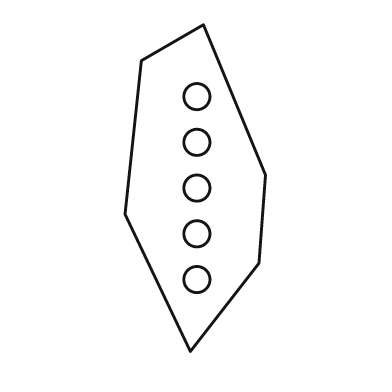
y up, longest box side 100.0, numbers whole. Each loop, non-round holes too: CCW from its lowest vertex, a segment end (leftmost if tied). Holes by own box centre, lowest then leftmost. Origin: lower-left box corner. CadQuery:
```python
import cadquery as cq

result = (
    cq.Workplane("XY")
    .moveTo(20.0, 0.0)
    .lineTo(41.0, 27.0)
    .lineTo(43.0, 54.0)
    .lineTo(24.0, 100.0)
    .lineTo(5.0, 89.0)
    .lineTo(0.0, 42.0)
    .close()
    .moveTo(22.0, 22.0)
    .circle(4.0)
    .moveTo(22.0, 36.0)
    .circle(4.0)
    .moveTo(22.0, 50.0)
    .circle(4.0)
    .moveTo(22.0, 64.0)
    .circle(4.0)
    .moveTo(22.0, 78.0)
    .circle(4.0)
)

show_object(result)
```